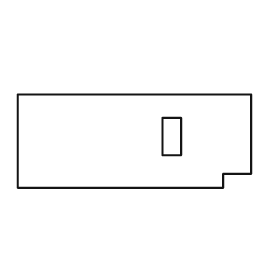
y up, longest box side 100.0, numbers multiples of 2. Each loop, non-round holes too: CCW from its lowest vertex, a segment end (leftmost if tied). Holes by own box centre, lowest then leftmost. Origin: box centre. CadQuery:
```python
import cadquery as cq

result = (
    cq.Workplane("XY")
    .moveTo(-50.0, -20.0)
    .lineTo(38.0, -20.0)
    .lineTo(38.0, -14.0)
    .lineTo(50.0, -14.0)
    .lineTo(50.0, 20.0)
    .lineTo(-50.0, 20.0)
    .close()
    .moveTo(12.0, -6.0)
    .lineTo(20.0, -6.0)
    .lineTo(20.0, 10.0)
    .lineTo(12.0, 10.0)
    .close()
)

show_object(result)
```